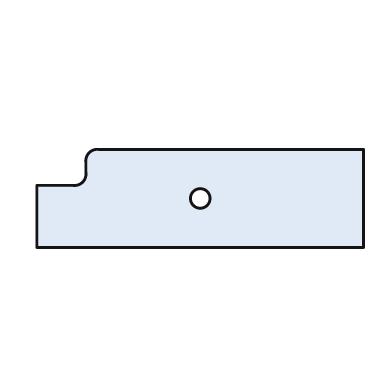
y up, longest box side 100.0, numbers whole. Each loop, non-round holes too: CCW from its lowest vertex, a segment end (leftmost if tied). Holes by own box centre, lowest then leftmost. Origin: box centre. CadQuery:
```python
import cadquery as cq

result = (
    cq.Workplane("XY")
    .moveTo(-50.0, -15.0)
    .lineTo(50.0, -15.0)
    .lineTo(50.0, 15.0)
    .lineTo(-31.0, 15.0)
    .threePointArc((-34.0, 14.0), (-35.0, 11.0))
    .lineTo(-35.0, 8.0)
    .threePointArc((-36.0, 5.0), (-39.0, 4.0))
    .lineTo(-50.0, 4.0)
    .close()
    .moveTo(0.0, 0.0)
    .circle(3.0)
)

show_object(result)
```